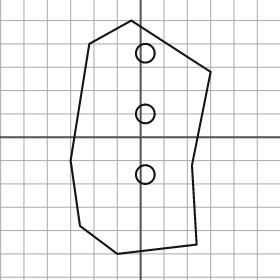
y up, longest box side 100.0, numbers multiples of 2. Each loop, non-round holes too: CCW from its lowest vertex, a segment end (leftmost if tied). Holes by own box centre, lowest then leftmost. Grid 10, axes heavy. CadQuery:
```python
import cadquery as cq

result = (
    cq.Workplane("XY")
    .moveTo(-10.0, -50.0)
    .lineTo(24.0, -46.0)
    .lineTo(22.0, -12.0)
    .lineTo(30.0, 28.0)
    .lineTo(-4.0, 50.0)
    .lineTo(-22.0, 40.0)
    .lineTo(-30.0, -10.0)
    .lineTo(-26.0, -38.0)
    .close()
    .moveTo(2.0, -16.0)
    .circle(4.0)
    .moveTo(2.0, 10.0)
    .circle(4.0)
    .moveTo(2.0, 36.0)
    .circle(4.0)
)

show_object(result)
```